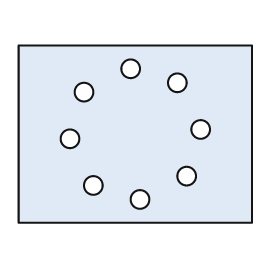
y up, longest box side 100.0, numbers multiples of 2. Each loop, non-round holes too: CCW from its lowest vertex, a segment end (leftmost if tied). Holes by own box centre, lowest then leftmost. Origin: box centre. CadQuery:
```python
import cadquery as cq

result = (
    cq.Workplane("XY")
    .moveTo(-50.0, -38.0)
    .lineTo(50.0, -38.0)
    .lineTo(50.0, 38.0)
    .lineTo(-50.0, 38.0)
    .close()
    .moveTo(2.0, -28.0)
    .circle(4.0)
    .moveTo(-18.0, -22.0)
    .circle(4.0)
    .moveTo(22.0, -18.0)
    .circle(4.0)
    .moveTo(-28.0, -2.0)
    .circle(4.0)
    .moveTo(28.0, 2.0)
    .circle(4.0)
    .moveTo(-22.0, 18.0)
    .circle(4.0)
    .moveTo(18.0, 22.0)
    .circle(4.0)
    .moveTo(-2.0, 28.0)
    .circle(4.0)
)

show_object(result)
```